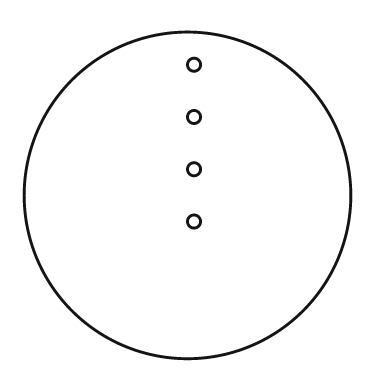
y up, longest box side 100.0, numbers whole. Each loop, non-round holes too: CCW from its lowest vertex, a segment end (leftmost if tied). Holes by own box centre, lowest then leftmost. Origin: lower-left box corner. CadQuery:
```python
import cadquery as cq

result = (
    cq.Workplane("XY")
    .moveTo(50.0, 50.0)
    .circle(50.0)
    .moveTo(52.0, 42.0)
    .circle(2.0)
    .moveTo(52.0, 58.0)
    .circle(2.0)
    .moveTo(52.0, 74.0)
    .circle(2.0)
    .moveTo(52.0, 90.0)
    .circle(2.0)
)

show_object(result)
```